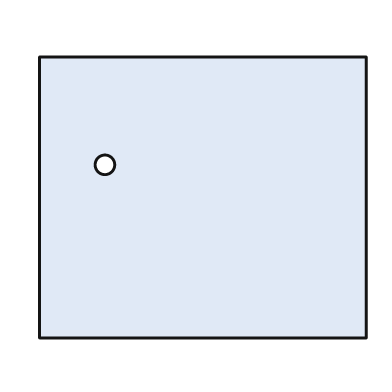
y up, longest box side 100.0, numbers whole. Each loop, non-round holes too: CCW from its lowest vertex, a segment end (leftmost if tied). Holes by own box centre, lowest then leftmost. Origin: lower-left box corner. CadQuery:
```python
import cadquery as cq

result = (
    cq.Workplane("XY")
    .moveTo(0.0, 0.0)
    .lineTo(100.0, 0.0)
    .lineTo(100.0, 86.0)
    .lineTo(0.0, 86.0)
    .close()
    .moveTo(20.0, 53.0)
    .circle(3.0)
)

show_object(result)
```